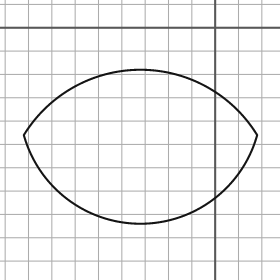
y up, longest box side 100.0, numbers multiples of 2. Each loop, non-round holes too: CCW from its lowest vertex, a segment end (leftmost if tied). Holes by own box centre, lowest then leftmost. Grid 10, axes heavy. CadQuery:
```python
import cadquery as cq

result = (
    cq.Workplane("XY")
    .moveTo(-82.0, -46.0)
    .threePointArc((-32.0, -84.0), (18.0, -46.0))
    .threePointArc((-32.0, -18.0), (-82.0, -46.0))
    .close()
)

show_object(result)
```